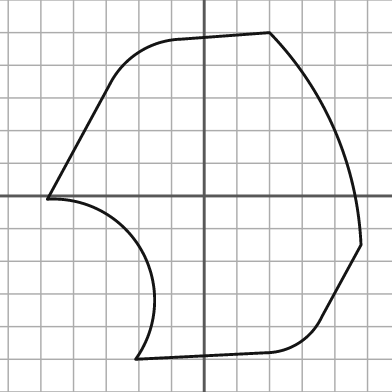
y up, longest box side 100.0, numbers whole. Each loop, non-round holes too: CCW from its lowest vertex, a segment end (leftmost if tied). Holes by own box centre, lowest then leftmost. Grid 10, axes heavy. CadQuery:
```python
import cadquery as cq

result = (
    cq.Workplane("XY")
    .moveTo(-21.0, -50.0)
    .lineTo(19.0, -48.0)
    .threePointArc((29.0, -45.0), (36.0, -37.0))
    .lineTo(48.0, -15.0)
    .threePointArc((40.0, 20.0), (20.0, 50.0))
    .lineTo(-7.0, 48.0)
    .threePointArc((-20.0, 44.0), (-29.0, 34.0))
    .lineTo(-48.0, -1.0)
    .threePointArc((-19.0, -17.0), (-21.0, -50.0))
    .close()
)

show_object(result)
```